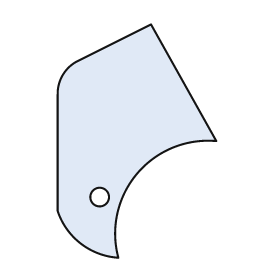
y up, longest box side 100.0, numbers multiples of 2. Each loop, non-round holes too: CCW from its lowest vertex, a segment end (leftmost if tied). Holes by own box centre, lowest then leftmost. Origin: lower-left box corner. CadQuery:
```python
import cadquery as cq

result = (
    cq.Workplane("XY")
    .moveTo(26.0, 0.0)
    .threePointArc((34.0, 36.0), (68.0, 50.0))
    .lineTo(40.0, 100.0)
    .lineTo(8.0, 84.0)
    .threePointArc((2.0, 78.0), (0.0, 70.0))
    .lineTo(0.0, 20.0)
    .threePointArc((10.0, 6.0), (26.0, 0.0))
    .close()
    .moveTo(18.0, 26.0)
    .circle(4.0)
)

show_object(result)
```